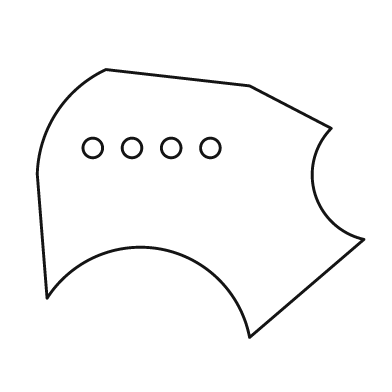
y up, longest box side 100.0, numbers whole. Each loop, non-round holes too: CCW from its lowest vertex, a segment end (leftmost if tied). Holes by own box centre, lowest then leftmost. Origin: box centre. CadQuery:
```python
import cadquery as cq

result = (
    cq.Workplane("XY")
    .moveTo(15.0, -41.0)
    .lineTo(50.0, -11.0)
    .threePointArc((35.0, 3.0), (40.0, 23.0))
    .lineTo(15.0, 36.0)
    .lineTo(-29.0, 41.0)
    .threePointArc((-44.0, 28.0), (-50.0, 9.0))
    .lineTo(-47.0, -29.0)
    .threePointArc((-12.0, -14.0), (15.0, -41.0))
    .close()
    .moveTo(-33.0, 17.0)
    .circle(3.0)
    .moveTo(-21.0, 17.0)
    .circle(3.0)
    .moveTo(-9.0, 17.0)
    .circle(3.0)
    .moveTo(3.0, 17.0)
    .circle(3.0)
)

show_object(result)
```